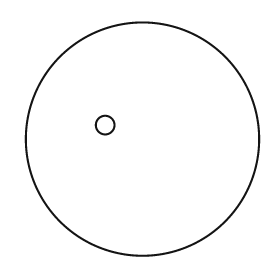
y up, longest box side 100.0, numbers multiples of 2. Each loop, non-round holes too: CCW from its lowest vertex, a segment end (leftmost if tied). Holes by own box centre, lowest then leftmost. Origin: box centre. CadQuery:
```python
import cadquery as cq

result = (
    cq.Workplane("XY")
    .moveTo(0.0, 0.0)
    .circle(50.0)
    .moveTo(-16.0, 6.0)
    .circle(4.0)
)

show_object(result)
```